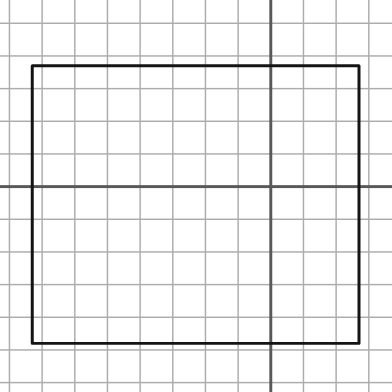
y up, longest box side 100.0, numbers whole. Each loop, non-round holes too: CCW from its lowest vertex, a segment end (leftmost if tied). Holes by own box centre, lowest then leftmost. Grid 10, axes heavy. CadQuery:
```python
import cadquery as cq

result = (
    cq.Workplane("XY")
    .moveTo(-73.0, -48.0)
    .lineTo(27.0, -48.0)
    .lineTo(27.0, 37.0)
    .lineTo(-73.0, 37.0)
    .close()
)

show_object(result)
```